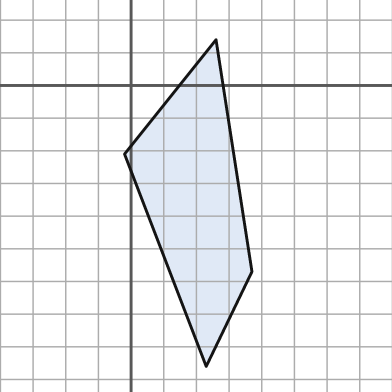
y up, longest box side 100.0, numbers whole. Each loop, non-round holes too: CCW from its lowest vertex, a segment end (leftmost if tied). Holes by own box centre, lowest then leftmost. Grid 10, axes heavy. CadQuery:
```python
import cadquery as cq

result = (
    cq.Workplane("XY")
    .moveTo(23.0, -86.0)
    .lineTo(37.0, -57.0)
    .lineTo(26.0, 14.0)
    .lineTo(-2.0, -21.0)
    .close()
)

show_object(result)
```